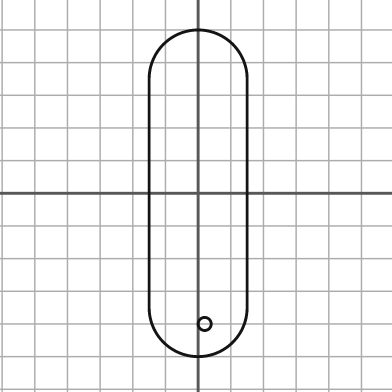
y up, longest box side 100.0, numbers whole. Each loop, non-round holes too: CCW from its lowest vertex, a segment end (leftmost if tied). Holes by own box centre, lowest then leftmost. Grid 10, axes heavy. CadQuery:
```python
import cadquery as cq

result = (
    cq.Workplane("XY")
    .moveTo(-15.0, -35.0)
    .threePointArc((0.0, -50.0), (15.0, -35.0))
    .lineTo(15.0, 35.0)
    .threePointArc((0.0, 50.0), (-15.0, 35.0))
    .close()
    .moveTo(2.0, -40.0)
    .circle(2.0)
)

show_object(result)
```